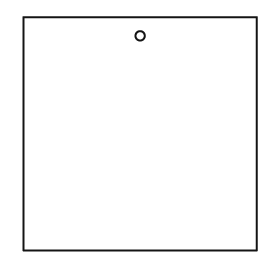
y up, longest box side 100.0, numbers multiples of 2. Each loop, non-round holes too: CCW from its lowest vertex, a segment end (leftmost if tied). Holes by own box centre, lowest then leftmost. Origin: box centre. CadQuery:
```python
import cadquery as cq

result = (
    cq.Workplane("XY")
    .moveTo(-50.0, -50.0)
    .lineTo(50.0, -50.0)
    .lineTo(50.0, 50.0)
    .lineTo(-50.0, 50.0)
    .close()
    .moveTo(0.0, 42.0)
    .circle(2.0)
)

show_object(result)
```